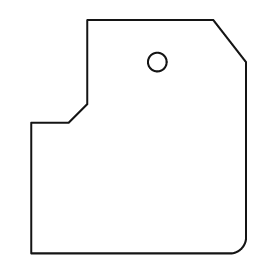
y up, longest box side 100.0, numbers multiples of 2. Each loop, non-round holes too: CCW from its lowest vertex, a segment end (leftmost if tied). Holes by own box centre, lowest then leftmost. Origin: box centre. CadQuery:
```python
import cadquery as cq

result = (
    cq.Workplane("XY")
    .moveTo(-46.0, -50.0)
    .lineTo(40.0, -50.0)
    .threePointArc((44.0, -48.0), (46.0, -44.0))
    .lineTo(46.0, 32.0)
    .lineTo(32.0, 50.0)
    .lineTo(-22.0, 50.0)
    .lineTo(-22.0, 14.0)
    .lineTo(-30.0, 6.0)
    .lineTo(-46.0, 6.0)
    .close()
    .moveTo(8.0, 32.0)
    .circle(4.0)
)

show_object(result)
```